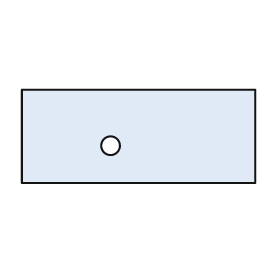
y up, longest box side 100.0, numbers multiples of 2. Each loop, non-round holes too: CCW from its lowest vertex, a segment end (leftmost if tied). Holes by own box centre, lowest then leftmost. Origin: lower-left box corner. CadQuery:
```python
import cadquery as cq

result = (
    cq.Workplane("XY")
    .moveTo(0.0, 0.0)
    .lineTo(100.0, 0.0)
    .lineTo(100.0, 40.0)
    .lineTo(0.0, 40.0)
    .close()
    .moveTo(38.0, 16.0)
    .circle(4.0)
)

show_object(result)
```